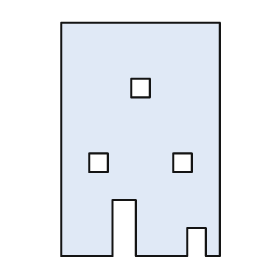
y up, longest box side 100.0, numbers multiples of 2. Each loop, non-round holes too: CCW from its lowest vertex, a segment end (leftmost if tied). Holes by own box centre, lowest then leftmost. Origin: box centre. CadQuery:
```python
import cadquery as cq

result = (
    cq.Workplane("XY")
    .moveTo(-34.0, -50.0)
    .lineTo(-12.0, -50.0)
    .lineTo(-12.0, -26.0)
    .lineTo(-2.0, -26.0)
    .lineTo(-2.0, -50.0)
    .lineTo(20.0, -50.0)
    .lineTo(20.0, -38.0)
    .lineTo(28.0, -38.0)
    .lineTo(28.0, -50.0)
    .lineTo(34.0, -50.0)
    .lineTo(34.0, 50.0)
    .lineTo(-34.0, 50.0)
    .close()
    .moveTo(-22.0, -14.0)
    .lineTo(-14.0, -14.0)
    .lineTo(-14.0, -6.0)
    .lineTo(-22.0, -6.0)
    .close()
    .moveTo(14.0, -14.0)
    .lineTo(22.0, -14.0)
    .lineTo(22.0, -6.0)
    .lineTo(14.0, -6.0)
    .close()
    .moveTo(-4.0, 18.0)
    .lineTo(4.0, 18.0)
    .lineTo(4.0, 26.0)
    .lineTo(-4.0, 26.0)
    .close()
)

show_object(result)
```